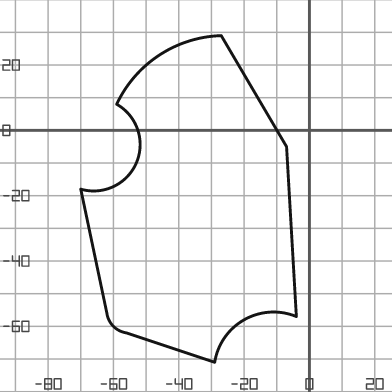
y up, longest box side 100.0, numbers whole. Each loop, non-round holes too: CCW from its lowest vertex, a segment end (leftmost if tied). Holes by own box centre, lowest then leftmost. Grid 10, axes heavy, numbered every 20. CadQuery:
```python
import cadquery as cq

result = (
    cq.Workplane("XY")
    .moveTo(-29.0, -71.0)
    .threePointArc((-20.0, -58.0), (-4.0, -57.0))
    .lineTo(-7.0, -5.0)
    .lineTo(-27.0, 29.0)
    .threePointArc((-46.0, 23.0), (-59.0, 8.0))
    .threePointArc((-53.0, -10.0), (-70.0, -18.0))
    .lineTo(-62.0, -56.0)
    .threePointArc((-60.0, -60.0), (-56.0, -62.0))
    .close()
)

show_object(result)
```